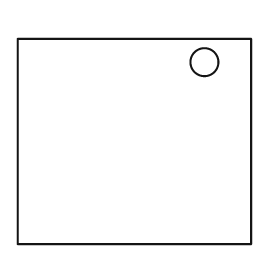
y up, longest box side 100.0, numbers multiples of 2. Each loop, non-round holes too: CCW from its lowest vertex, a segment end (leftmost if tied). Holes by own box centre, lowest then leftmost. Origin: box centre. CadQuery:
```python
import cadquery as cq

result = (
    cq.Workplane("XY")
    .moveTo(-50.0, -44.0)
    .lineTo(50.0, -44.0)
    .lineTo(50.0, 44.0)
    .lineTo(-50.0, 44.0)
    .close()
    .moveTo(30.0, 34.0)
    .circle(6.0)
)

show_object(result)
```